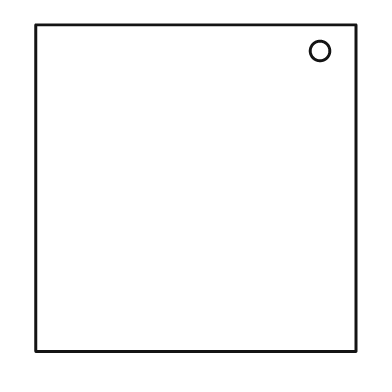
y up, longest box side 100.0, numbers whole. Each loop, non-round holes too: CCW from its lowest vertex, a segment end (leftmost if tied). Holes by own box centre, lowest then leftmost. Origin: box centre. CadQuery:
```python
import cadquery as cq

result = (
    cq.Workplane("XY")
    .moveTo(-49.0, -50.0)
    .lineTo(49.0, -50.0)
    .lineTo(49.0, 50.0)
    .lineTo(-49.0, 50.0)
    .close()
    .moveTo(38.0, 42.0)
    .circle(3.0)
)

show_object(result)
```